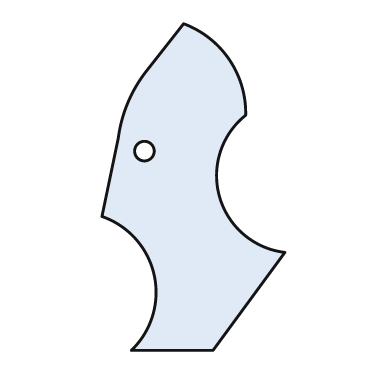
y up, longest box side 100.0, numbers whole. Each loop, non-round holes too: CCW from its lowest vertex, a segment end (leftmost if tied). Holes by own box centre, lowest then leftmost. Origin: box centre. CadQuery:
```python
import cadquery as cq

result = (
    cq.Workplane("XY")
    .moveTo(-19.0, -50.0)
    .lineTo(6.0, -50.0)
    .lineTo(28.0, -20.0)
    .threePointArc((8.0, -3.0), (16.0, 22.0))
    .threePointArc((11.0, 39.0), (-3.0, 50.0))
    .lineTo(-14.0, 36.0)
    .threePointArc((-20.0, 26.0), (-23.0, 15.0))
    .lineTo(-28.0, -9.0)
    .threePointArc((-12.0, -27.0), (-19.0, -50.0))
    .close()
    .moveTo(-15.0, 11.0)
    .circle(3.0)
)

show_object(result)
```